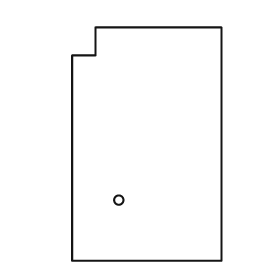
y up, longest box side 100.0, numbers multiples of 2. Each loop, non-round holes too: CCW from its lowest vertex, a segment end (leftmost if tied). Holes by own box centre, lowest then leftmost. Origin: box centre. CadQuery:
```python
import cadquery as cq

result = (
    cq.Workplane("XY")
    .moveTo(-32.0, -50.0)
    .lineTo(32.0, -50.0)
    .lineTo(32.0, 50.0)
    .lineTo(-22.0, 50.0)
    .lineTo(-22.0, 38.0)
    .lineTo(-32.0, 38.0)
    .close()
    .moveTo(-12.0, -24.0)
    .circle(2.0)
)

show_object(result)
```